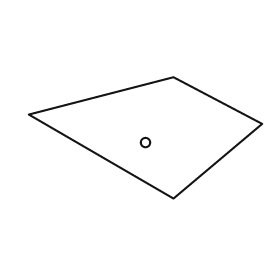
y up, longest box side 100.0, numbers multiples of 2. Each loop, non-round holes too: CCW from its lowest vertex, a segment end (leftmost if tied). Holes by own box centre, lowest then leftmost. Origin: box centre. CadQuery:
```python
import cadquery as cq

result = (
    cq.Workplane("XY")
    .moveTo(12.0, -26.0)
    .lineTo(50.0, 6.0)
    .lineTo(12.0, 26.0)
    .lineTo(-50.0, 10.0)
    .close()
    .moveTo(0.0, -2.0)
    .circle(2.0)
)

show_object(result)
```